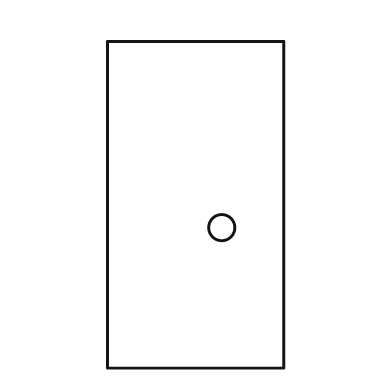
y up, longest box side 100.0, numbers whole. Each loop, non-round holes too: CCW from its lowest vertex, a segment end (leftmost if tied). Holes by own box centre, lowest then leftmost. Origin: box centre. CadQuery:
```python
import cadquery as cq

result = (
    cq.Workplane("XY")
    .moveTo(-27.0, -50.0)
    .lineTo(27.0, -50.0)
    .lineTo(27.0, 50.0)
    .lineTo(-27.0, 50.0)
    .close()
    .moveTo(8.0, -7.0)
    .circle(4.0)
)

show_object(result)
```